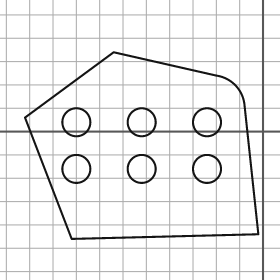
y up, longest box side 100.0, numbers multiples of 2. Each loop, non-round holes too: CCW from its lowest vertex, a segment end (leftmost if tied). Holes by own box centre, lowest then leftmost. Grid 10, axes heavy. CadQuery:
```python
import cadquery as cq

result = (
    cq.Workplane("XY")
    .moveTo(-82.0, -46.0)
    .lineTo(-2.0, -44.0)
    .lineTo(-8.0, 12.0)
    .threePointArc((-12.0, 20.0), (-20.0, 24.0))
    .lineTo(-64.0, 34.0)
    .lineTo(-102.0, 6.0)
    .close()
    .moveTo(-80.0, -16.0)
    .circle(6.0)
    .moveTo(-52.0, -16.0)
    .circle(6.0)
    .moveTo(-24.0, -16.0)
    .circle(6.0)
    .moveTo(-80.0, 4.0)
    .circle(6.0)
    .moveTo(-52.0, 4.0)
    .circle(6.0)
    .moveTo(-24.0, 4.0)
    .circle(6.0)
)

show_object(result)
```